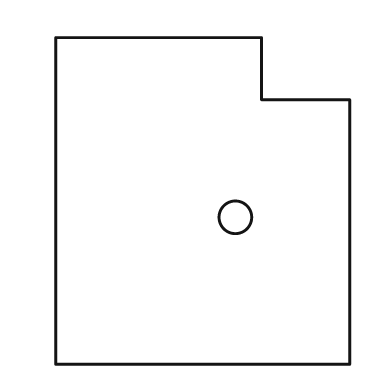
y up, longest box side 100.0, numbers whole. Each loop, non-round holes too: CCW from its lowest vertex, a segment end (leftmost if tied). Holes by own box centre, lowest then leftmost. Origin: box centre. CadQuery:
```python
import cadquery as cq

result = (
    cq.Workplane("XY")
    .moveTo(-45.0, -50.0)
    .lineTo(45.0, -50.0)
    .lineTo(45.0, 31.0)
    .lineTo(18.0, 31.0)
    .lineTo(18.0, 50.0)
    .lineTo(-45.0, 50.0)
    .close()
    .moveTo(10.0, -5.0)
    .circle(5.0)
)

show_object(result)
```